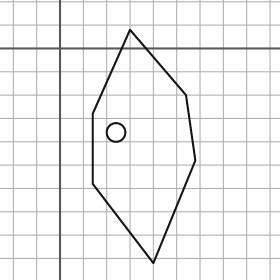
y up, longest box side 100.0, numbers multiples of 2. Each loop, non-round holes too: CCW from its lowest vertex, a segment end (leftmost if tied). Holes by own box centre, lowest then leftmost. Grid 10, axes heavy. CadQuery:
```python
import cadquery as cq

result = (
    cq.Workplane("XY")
    .moveTo(40.0, -92.0)
    .lineTo(58.0, -48.0)
    .lineTo(54.0, -20.0)
    .lineTo(30.0, 8.0)
    .lineTo(14.0, -28.0)
    .lineTo(14.0, -58.0)
    .close()
    .moveTo(24.0, -36.0)
    .circle(4.0)
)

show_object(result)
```